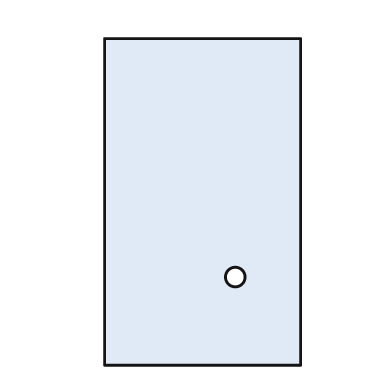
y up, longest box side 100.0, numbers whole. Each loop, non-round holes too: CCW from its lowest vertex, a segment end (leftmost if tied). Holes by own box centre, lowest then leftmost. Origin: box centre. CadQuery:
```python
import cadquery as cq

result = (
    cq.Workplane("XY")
    .moveTo(-30.0, -50.0)
    .lineTo(30.0, -50.0)
    .lineTo(30.0, 50.0)
    .lineTo(-30.0, 50.0)
    .close()
    .moveTo(10.0, -23.0)
    .circle(3.0)
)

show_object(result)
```